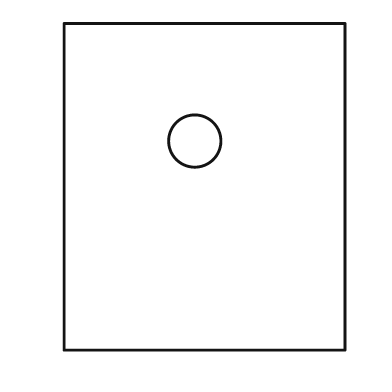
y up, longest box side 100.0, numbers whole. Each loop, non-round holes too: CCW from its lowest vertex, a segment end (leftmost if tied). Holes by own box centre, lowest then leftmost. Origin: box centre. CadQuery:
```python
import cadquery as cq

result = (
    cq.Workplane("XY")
    .moveTo(-43.0, -50.0)
    .lineTo(43.0, -50.0)
    .lineTo(43.0, 50.0)
    .lineTo(-43.0, 50.0)
    .close()
    .moveTo(-3.0, 14.0)
    .circle(8.0)
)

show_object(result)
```